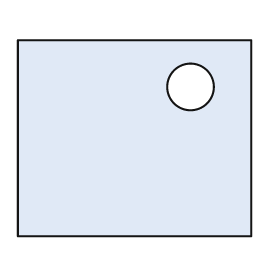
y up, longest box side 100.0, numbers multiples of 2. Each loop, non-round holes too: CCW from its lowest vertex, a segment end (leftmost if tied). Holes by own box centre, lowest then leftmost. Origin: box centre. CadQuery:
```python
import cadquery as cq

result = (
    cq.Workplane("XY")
    .moveTo(-50.0, -42.0)
    .lineTo(50.0, -42.0)
    .lineTo(50.0, 42.0)
    .lineTo(-50.0, 42.0)
    .close()
    .moveTo(24.0, 22.0)
    .circle(10.0)
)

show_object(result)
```